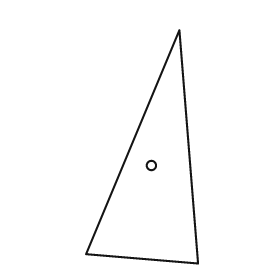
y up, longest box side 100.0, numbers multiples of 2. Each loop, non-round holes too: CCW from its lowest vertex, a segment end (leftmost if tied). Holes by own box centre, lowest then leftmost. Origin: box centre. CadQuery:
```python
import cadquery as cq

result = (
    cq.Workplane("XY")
    .moveTo(24.0, -50.0)
    .lineTo(16.0, 50.0)
    .lineTo(-24.0, -46.0)
    .close()
    .moveTo(4.0, -8.0)
    .circle(2.0)
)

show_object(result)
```